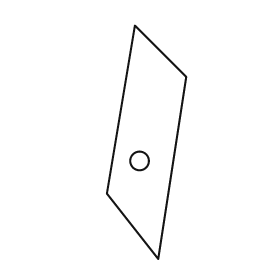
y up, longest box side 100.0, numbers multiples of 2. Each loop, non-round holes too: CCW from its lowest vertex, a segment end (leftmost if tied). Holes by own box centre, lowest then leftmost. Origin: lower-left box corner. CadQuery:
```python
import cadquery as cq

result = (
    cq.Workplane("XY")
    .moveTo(22.0, 0.0)
    .lineTo(34.0, 78.0)
    .lineTo(12.0, 100.0)
    .lineTo(0.0, 28.0)
    .close()
    .moveTo(14.0, 42.0)
    .circle(4.0)
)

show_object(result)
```